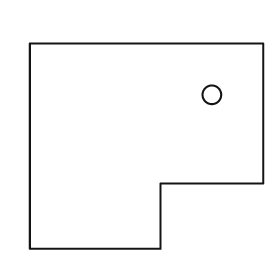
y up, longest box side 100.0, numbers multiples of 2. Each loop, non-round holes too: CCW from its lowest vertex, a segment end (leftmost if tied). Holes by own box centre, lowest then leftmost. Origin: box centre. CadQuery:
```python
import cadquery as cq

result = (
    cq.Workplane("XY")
    .moveTo(-50.0, -44.0)
    .lineTo(6.0, -44.0)
    .lineTo(6.0, -16.0)
    .lineTo(50.0, -16.0)
    .lineTo(50.0, 44.0)
    .lineTo(-50.0, 44.0)
    .close()
    .moveTo(28.0, 22.0)
    .circle(4.0)
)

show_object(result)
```